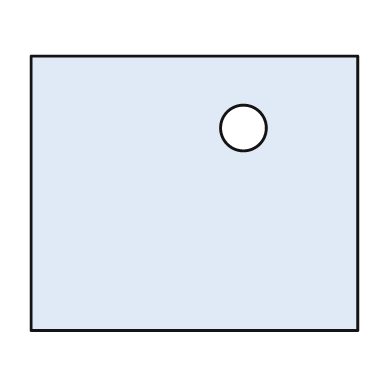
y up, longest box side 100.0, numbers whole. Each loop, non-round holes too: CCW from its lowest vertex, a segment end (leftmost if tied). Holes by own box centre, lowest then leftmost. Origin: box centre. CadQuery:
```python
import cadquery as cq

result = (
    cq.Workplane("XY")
    .moveTo(-50.0, -42.0)
    .lineTo(50.0, -42.0)
    .lineTo(50.0, 42.0)
    .lineTo(-50.0, 42.0)
    .close()
    .moveTo(15.0, 20.0)
    .circle(7.0)
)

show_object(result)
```